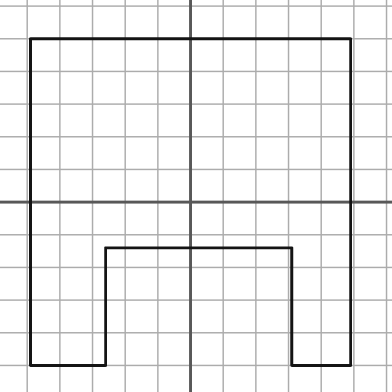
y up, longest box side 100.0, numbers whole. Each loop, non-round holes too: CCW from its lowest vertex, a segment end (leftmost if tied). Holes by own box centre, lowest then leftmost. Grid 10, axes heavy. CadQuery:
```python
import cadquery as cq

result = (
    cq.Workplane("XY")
    .moveTo(-49.0, -50.0)
    .lineTo(-26.0, -50.0)
    .lineTo(-26.0, -14.0)
    .lineTo(31.0, -14.0)
    .lineTo(31.0, -50.0)
    .lineTo(49.0, -50.0)
    .lineTo(49.0, 50.0)
    .lineTo(-49.0, 50.0)
    .close()
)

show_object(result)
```